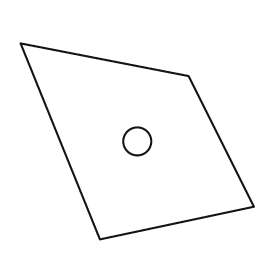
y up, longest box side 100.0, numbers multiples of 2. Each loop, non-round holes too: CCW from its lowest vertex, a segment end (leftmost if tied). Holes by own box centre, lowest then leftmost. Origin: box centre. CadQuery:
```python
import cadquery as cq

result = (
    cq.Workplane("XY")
    .moveTo(-16.0, -42.0)
    .lineTo(50.0, -28.0)
    .lineTo(22.0, 28.0)
    .lineTo(-50.0, 42.0)
    .close()
    .moveTo(0.0, 0.0)
    .circle(6.0)
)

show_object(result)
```